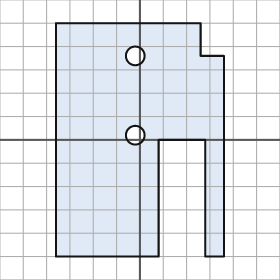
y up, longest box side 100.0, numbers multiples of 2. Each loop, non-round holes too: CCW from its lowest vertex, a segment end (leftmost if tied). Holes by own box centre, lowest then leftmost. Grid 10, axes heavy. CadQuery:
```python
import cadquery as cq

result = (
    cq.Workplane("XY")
    .moveTo(-36.0, -50.0)
    .lineTo(8.0, -50.0)
    .lineTo(8.0, 0.0)
    .lineTo(28.0, 0.0)
    .lineTo(28.0, -50.0)
    .lineTo(36.0, -50.0)
    .lineTo(36.0, 36.0)
    .lineTo(26.0, 36.0)
    .lineTo(26.0, 50.0)
    .lineTo(-36.0, 50.0)
    .close()
    .moveTo(-2.0, 2.0)
    .circle(4.0)
    .moveTo(-2.0, 36.0)
    .circle(4.0)
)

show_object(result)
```